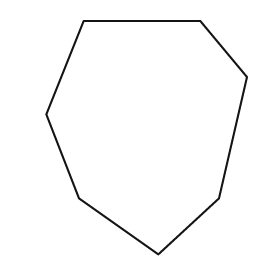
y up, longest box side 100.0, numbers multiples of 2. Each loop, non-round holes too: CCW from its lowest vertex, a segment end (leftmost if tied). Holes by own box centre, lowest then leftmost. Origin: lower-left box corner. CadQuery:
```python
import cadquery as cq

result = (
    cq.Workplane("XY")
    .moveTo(48.0, 0.0)
    .lineTo(74.0, 24.0)
    .lineTo(86.0, 76.0)
    .lineTo(66.0, 100.0)
    .lineTo(16.0, 100.0)
    .lineTo(0.0, 60.0)
    .lineTo(14.0, 24.0)
    .close()
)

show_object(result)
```